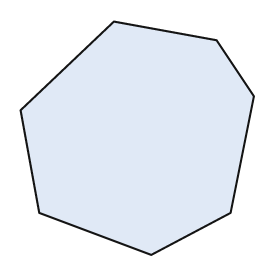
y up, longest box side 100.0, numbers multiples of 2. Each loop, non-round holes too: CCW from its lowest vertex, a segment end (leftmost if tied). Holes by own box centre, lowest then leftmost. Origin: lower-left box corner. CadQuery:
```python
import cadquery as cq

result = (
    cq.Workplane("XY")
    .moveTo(56.0, 0.0)
    .lineTo(90.0, 18.0)
    .lineTo(100.0, 68.0)
    .lineTo(84.0, 92.0)
    .lineTo(40.0, 100.0)
    .lineTo(0.0, 62.0)
    .lineTo(8.0, 18.0)
    .close()
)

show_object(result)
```